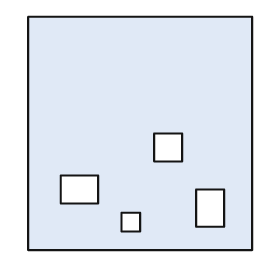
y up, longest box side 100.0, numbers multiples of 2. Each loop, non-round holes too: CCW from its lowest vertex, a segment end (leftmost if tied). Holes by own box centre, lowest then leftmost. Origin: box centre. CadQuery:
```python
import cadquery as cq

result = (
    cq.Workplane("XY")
    .moveTo(-48.0, -50.0)
    .lineTo(48.0, -50.0)
    .lineTo(48.0, 50.0)
    .lineTo(-48.0, 50.0)
    .close()
    .moveTo(-8.0, -42.0)
    .lineTo(0.0, -42.0)
    .lineTo(0.0, -34.0)
    .lineTo(-8.0, -34.0)
    .close()
    .moveTo(24.0, -40.0)
    .lineTo(36.0, -40.0)
    .lineTo(36.0, -24.0)
    .lineTo(24.0, -24.0)
    .close()
    .moveTo(-34.0, -30.0)
    .lineTo(-18.0, -30.0)
    .lineTo(-18.0, -18.0)
    .lineTo(-34.0, -18.0)
    .close()
    .moveTo(6.0, -12.0)
    .lineTo(18.0, -12.0)
    .lineTo(18.0, 0.0)
    .lineTo(6.0, 0.0)
    .close()
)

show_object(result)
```